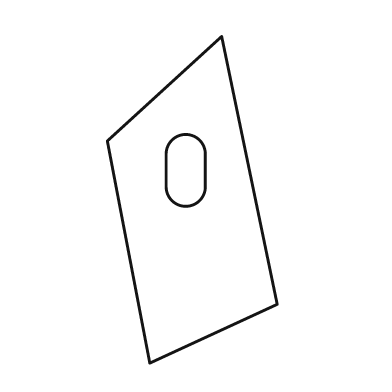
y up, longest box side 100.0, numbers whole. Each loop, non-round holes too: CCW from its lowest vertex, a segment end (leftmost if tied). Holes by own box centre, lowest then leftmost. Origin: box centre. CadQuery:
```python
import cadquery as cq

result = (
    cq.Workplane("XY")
    .moveTo(-13.0, -50.0)
    .lineTo(26.0, -32.0)
    .lineTo(9.0, 50.0)
    .lineTo(-26.0, 18.0)
    .close()
    .moveTo(-8.0, 4.0)
    .threePointArc((-2.0, -2.0), (4.0, 4.0))
    .lineTo(4.0, 14.0)
    .threePointArc((-2.0, 20.0), (-8.0, 14.0))
    .close()
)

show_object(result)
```